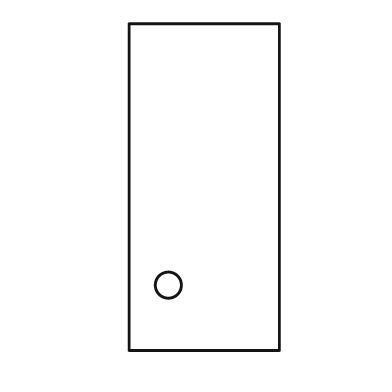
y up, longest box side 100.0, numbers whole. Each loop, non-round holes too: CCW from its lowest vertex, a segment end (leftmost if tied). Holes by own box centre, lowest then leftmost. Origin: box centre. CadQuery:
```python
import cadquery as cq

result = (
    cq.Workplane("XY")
    .moveTo(-23.0, -50.0)
    .lineTo(23.0, -50.0)
    .lineTo(23.0, 50.0)
    .lineTo(-23.0, 50.0)
    .close()
    .moveTo(-11.0, -30.0)
    .circle(4.0)
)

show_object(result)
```